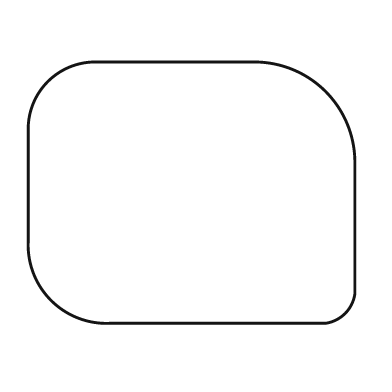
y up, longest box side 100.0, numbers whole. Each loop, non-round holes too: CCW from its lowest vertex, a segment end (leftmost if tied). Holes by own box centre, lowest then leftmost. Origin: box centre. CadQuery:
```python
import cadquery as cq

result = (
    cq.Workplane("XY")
    .moveTo(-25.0, -40.0)
    .lineTo(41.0, -40.0)
    .threePointArc((47.0, -37.0), (50.0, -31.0))
    .lineTo(50.0, 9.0)
    .threePointArc((41.0, 31.0), (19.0, 40.0))
    .lineTo(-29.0, 40.0)
    .threePointArc((-44.0, 34.0), (-50.0, 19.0))
    .lineTo(-50.0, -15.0)
    .threePointArc((-43.0, -33.0), (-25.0, -40.0))
    .close()
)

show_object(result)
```